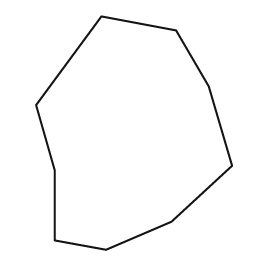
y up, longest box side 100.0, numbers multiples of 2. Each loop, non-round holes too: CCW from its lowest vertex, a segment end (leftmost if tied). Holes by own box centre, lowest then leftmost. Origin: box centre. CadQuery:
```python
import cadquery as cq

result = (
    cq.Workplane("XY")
    .moveTo(-12.0, -50.0)
    .lineTo(16.0, -38.0)
    .lineTo(42.0, -14.0)
    .lineTo(32.0, 20.0)
    .lineTo(18.0, 44.0)
    .lineTo(-14.0, 50.0)
    .lineTo(-42.0, 12.0)
    .lineTo(-34.0, -16.0)
    .lineTo(-34.0, -46.0)
    .close()
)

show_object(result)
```